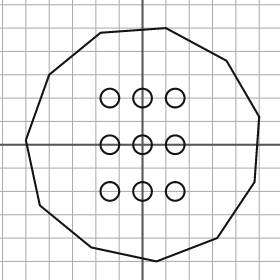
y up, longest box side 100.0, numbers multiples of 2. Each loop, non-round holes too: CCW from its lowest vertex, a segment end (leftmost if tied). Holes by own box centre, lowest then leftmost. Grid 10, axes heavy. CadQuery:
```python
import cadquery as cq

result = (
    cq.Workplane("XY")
    .moveTo(6.0, -50.0)
    .lineTo(32.0, -40.0)
    .lineTo(48.0, -16.0)
    .lineTo(50.0, 12.0)
    .lineTo(36.0, 36.0)
    .lineTo(10.0, 50.0)
    .lineTo(-18.0, 48.0)
    .lineTo(-40.0, 30.0)
    .lineTo(-50.0, 2.0)
    .lineTo(-44.0, -26.0)
    .lineTo(-22.0, -44.0)
    .close()
    .moveTo(-14.0, -20.0)
    .circle(4.0)
    .moveTo(0.0, -20.0)
    .circle(4.0)
    .moveTo(14.0, -20.0)
    .circle(4.0)
    .moveTo(-14.0, 0.0)
    .circle(4.0)
    .moveTo(0.0, 0.0)
    .circle(4.0)
    .moveTo(14.0, 0.0)
    .circle(4.0)
    .moveTo(-14.0, 20.0)
    .circle(4.0)
    .moveTo(0.0, 20.0)
    .circle(4.0)
    .moveTo(14.0, 20.0)
    .circle(4.0)
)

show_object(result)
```